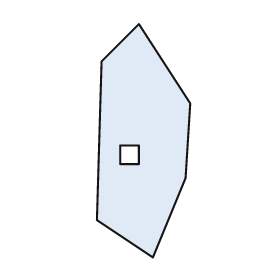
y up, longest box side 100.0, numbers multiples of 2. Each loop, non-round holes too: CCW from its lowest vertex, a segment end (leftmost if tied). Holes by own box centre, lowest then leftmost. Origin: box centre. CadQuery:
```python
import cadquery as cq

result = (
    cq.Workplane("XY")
    .moveTo(4.0, -50.0)
    .lineTo(18.0, -16.0)
    .lineTo(20.0, 16.0)
    .lineTo(-2.0, 50.0)
    .lineTo(-18.0, 34.0)
    .lineTo(-20.0, -34.0)
    .close()
    .moveTo(-10.0, -10.0)
    .lineTo(-2.0, -10.0)
    .lineTo(-2.0, -2.0)
    .lineTo(-10.0, -2.0)
    .close()
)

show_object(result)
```